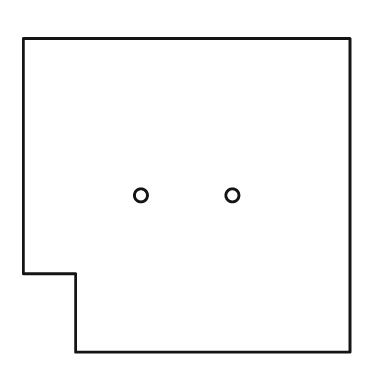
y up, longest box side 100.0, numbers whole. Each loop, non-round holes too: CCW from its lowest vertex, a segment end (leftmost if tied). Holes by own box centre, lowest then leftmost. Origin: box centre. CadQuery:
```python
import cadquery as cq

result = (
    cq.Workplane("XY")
    .moveTo(-34.0, -48.0)
    .lineTo(50.0, -48.0)
    .lineTo(50.0, 48.0)
    .lineTo(-50.0, 48.0)
    .lineTo(-50.0, -24.0)
    .lineTo(-34.0, -24.0)
    .close()
    .moveTo(-14.0, 0.0)
    .circle(2.0)
    .moveTo(14.0, 0.0)
    .circle(2.0)
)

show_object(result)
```